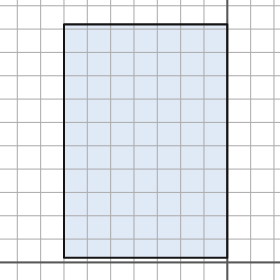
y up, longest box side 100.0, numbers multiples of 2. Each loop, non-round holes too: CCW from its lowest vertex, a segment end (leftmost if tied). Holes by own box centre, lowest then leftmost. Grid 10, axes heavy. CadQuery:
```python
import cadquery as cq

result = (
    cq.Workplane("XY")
    .moveTo(-70.0, 2.0)
    .lineTo(0.0, 2.0)
    .lineTo(0.0, 102.0)
    .lineTo(-70.0, 102.0)
    .close()
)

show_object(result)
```